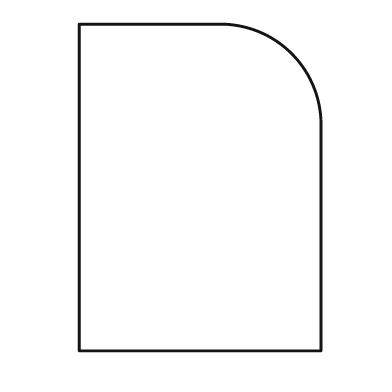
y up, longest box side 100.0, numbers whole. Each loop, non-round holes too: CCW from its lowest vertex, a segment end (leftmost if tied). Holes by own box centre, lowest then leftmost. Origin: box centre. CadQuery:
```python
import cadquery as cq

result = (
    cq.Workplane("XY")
    .moveTo(-37.0, -50.0)
    .lineTo(37.0, -50.0)
    .lineTo(37.0, 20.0)
    .threePointArc((28.0, 41.0), (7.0, 50.0))
    .lineTo(-37.0, 50.0)
    .close()
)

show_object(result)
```